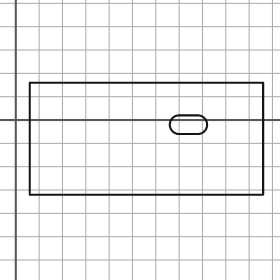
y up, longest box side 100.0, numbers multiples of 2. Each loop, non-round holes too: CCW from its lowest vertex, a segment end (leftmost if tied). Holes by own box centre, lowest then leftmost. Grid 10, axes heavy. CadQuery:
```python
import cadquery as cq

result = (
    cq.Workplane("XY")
    .moveTo(6.0, -32.0)
    .lineTo(106.0, -32.0)
    .lineTo(106.0, 16.0)
    .lineTo(6.0, 16.0)
    .close()
    .moveTo(70.0, -6.0)
    .lineTo(78.0, -6.0)
    .threePointArc((82.0, -2.0), (78.0, 2.0))
    .lineTo(70.0, 2.0)
    .threePointArc((66.0, -2.0), (70.0, -6.0))
    .close()
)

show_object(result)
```